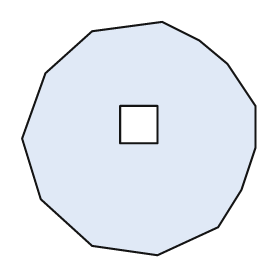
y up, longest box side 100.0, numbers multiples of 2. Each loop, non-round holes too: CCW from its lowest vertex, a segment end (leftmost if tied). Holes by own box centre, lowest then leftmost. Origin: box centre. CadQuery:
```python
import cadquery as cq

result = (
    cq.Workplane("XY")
    .moveTo(8.0, -50.0)
    .lineTo(34.0, -38.0)
    .lineTo(44.0, -22.0)
    .lineTo(50.0, -4.0)
    .lineTo(50.0, 14.0)
    .lineTo(38.0, 32.0)
    .lineTo(26.0, 42.0)
    .lineTo(10.0, 50.0)
    .lineTo(-20.0, 46.0)
    .lineTo(-40.0, 28.0)
    .lineTo(-50.0, 0.0)
    .lineTo(-42.0, -26.0)
    .lineTo(-20.0, -46.0)
    .close()
    .moveTo(-8.0, -2.0)
    .lineTo(8.0, -2.0)
    .lineTo(8.0, 14.0)
    .lineTo(-8.0, 14.0)
    .close()
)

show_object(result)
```